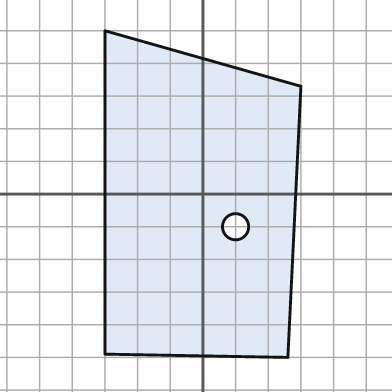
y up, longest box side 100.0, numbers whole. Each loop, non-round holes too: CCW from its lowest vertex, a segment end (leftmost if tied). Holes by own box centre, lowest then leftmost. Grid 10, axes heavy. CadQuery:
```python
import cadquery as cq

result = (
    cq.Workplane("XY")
    .moveTo(26.0, -50.0)
    .lineTo(30.0, 33.0)
    .lineTo(-30.0, 50.0)
    .lineTo(-30.0, -49.0)
    .close()
    .moveTo(10.0, -10.0)
    .circle(4.0)
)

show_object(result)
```